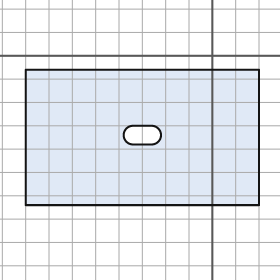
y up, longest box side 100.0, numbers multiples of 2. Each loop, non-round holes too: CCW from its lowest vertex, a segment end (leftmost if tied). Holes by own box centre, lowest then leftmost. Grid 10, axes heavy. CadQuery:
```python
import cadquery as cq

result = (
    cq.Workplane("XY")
    .moveTo(-80.0, -64.0)
    .lineTo(20.0, -64.0)
    .lineTo(20.0, -6.0)
    .lineTo(-80.0, -6.0)
    .close()
    .moveTo(-34.0, -38.0)
    .lineTo(-26.0, -38.0)
    .threePointArc((-22.0, -34.0), (-26.0, -30.0))
    .lineTo(-34.0, -30.0)
    .threePointArc((-38.0, -34.0), (-34.0, -38.0))
    .close()
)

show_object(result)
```